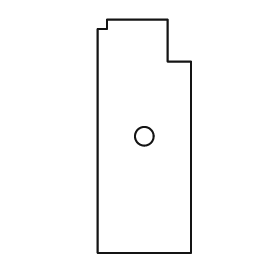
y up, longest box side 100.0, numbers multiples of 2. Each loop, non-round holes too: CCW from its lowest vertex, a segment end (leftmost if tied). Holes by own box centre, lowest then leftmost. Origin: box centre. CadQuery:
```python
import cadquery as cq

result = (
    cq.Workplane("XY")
    .moveTo(-20.0, -50.0)
    .lineTo(20.0, -50.0)
    .lineTo(20.0, 32.0)
    .lineTo(10.0, 32.0)
    .lineTo(10.0, 50.0)
    .lineTo(-16.0, 50.0)
    .lineTo(-16.0, 46.0)
    .lineTo(-20.0, 46.0)
    .close()
    .moveTo(0.0, 0.0)
    .circle(4.0)
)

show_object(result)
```